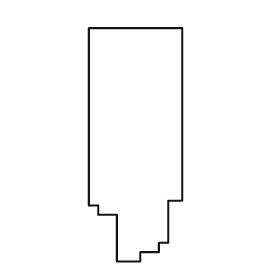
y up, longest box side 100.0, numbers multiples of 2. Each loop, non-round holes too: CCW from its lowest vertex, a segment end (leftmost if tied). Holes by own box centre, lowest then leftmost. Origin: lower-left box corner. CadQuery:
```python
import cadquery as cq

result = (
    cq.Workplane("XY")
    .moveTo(12.0, 0.0)
    .lineTo(22.0, 0.0)
    .lineTo(22.0, 4.0)
    .lineTo(30.0, 4.0)
    .lineTo(30.0, 8.0)
    .lineTo(34.0, 8.0)
    .lineTo(34.0, 26.0)
    .lineTo(40.0, 26.0)
    .lineTo(40.0, 100.0)
    .lineTo(0.0, 100.0)
    .lineTo(0.0, 24.0)
    .lineTo(4.0, 24.0)
    .lineTo(4.0, 20.0)
    .lineTo(12.0, 20.0)
    .close()
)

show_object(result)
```